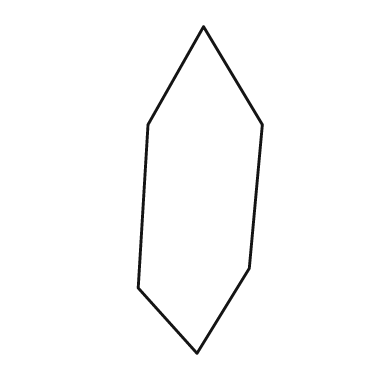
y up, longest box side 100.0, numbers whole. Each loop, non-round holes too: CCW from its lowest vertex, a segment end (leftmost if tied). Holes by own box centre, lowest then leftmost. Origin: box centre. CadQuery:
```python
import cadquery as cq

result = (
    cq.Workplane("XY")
    .moveTo(-1.0, -50.0)
    .lineTo(15.0, -24.0)
    .lineTo(19.0, 20.0)
    .lineTo(1.0, 50.0)
    .lineTo(-16.0, 20.0)
    .lineTo(-19.0, -30.0)
    .close()
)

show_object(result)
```